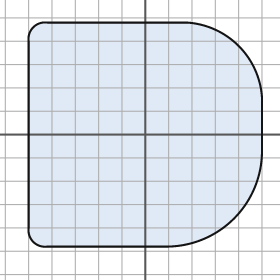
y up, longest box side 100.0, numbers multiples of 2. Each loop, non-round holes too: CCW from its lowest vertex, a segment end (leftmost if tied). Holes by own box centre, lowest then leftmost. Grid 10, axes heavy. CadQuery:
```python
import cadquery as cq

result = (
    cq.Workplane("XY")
    .moveTo(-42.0, -48.0)
    .lineTo(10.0, -48.0)
    .threePointArc((38.0, -36.0), (50.0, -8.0))
    .lineTo(50.0, 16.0)
    .threePointArc((40.0, 38.0), (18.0, 48.0))
    .lineTo(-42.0, 48.0)
    .threePointArc((-48.0, 46.0), (-50.0, 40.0))
    .lineTo(-50.0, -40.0)
    .threePointArc((-48.0, -46.0), (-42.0, -48.0))
    .close()
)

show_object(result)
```